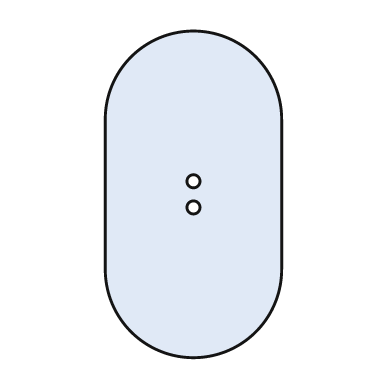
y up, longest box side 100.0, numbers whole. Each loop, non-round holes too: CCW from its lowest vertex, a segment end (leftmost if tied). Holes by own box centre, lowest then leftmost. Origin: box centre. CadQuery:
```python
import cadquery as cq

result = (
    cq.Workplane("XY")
    .moveTo(-27.0, -23.0)
    .threePointArc((0.0, -50.0), (27.0, -23.0))
    .lineTo(27.0, 23.0)
    .threePointArc((0.0, 50.0), (-27.0, 23.0))
    .close()
    .moveTo(0.0, -4.0)
    .circle(2.0)
    .moveTo(0.0, 4.0)
    .circle(2.0)
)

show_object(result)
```